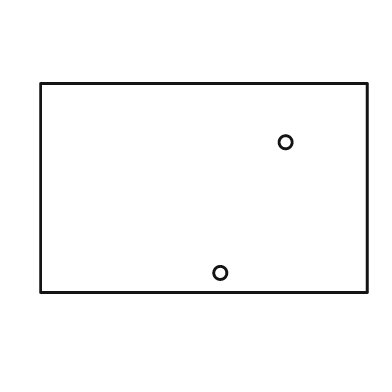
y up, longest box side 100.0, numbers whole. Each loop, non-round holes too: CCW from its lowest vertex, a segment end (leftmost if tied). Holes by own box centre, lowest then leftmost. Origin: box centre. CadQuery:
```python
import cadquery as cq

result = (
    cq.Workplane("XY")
    .moveTo(-50.0, -32.0)
    .lineTo(50.0, -32.0)
    .lineTo(50.0, 32.0)
    .lineTo(-50.0, 32.0)
    .close()
    .moveTo(5.0, -26.0)
    .circle(2.0)
    .moveTo(25.0, 14.0)
    .circle(2.0)
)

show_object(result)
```